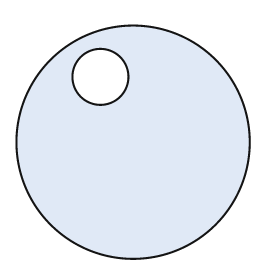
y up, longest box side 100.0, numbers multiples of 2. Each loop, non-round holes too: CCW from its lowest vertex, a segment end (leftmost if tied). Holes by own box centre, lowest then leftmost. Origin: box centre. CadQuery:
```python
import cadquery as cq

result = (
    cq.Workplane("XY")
    .moveTo(0.0, 0.0)
    .circle(50.0)
    .moveTo(-14.0, 28.0)
    .circle(12.0)
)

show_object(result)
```